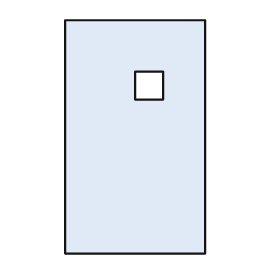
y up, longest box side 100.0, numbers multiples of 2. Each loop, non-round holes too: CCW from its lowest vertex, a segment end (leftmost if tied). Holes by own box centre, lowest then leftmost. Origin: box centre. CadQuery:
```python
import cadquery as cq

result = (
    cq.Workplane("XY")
    .moveTo(-30.0, -50.0)
    .lineTo(30.0, -50.0)
    .lineTo(30.0, 50.0)
    .lineTo(-30.0, 50.0)
    .close()
    .moveTo(0.0, 16.0)
    .lineTo(12.0, 16.0)
    .lineTo(12.0, 28.0)
    .lineTo(0.0, 28.0)
    .close()
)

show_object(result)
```